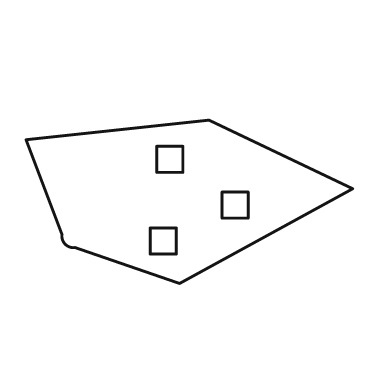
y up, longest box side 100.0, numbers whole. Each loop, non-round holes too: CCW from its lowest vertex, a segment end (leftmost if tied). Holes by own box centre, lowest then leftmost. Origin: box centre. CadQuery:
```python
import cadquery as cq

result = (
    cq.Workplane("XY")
    .moveTo(-3.0, -25.0)
    .lineTo(50.0, 4.0)
    .lineTo(6.0, 25.0)
    .lineTo(-50.0, 19.0)
    .lineTo(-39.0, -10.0)
    .threePointArc((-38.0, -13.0), (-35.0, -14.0))
    .close()
    .moveTo(-12.0, -16.0)
    .lineTo(-4.0, -16.0)
    .lineTo(-4.0, -8.0)
    .lineTo(-12.0, -8.0)
    .close()
    .moveTo(10.0, -5.0)
    .lineTo(18.0, -5.0)
    .lineTo(18.0, 3.0)
    .lineTo(10.0, 3.0)
    .close()
    .moveTo(-10.0, 9.0)
    .lineTo(-2.0, 9.0)
    .lineTo(-2.0, 17.0)
    .lineTo(-10.0, 17.0)
    .close()
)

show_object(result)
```